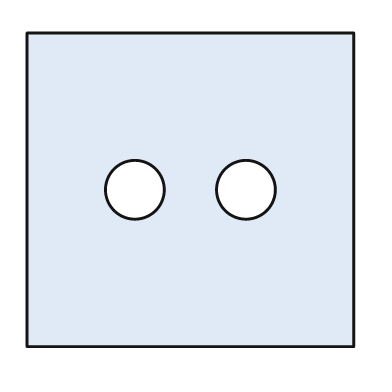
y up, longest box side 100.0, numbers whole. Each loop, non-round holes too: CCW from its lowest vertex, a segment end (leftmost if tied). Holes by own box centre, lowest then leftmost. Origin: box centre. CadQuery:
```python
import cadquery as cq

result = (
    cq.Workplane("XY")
    .moveTo(-50.0, -48.0)
    .lineTo(50.0, -48.0)
    .lineTo(50.0, 48.0)
    .lineTo(-50.0, 48.0)
    .close()
    .moveTo(-17.0, 0.0)
    .circle(9.0)
    .moveTo(17.0, 0.0)
    .circle(9.0)
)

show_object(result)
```